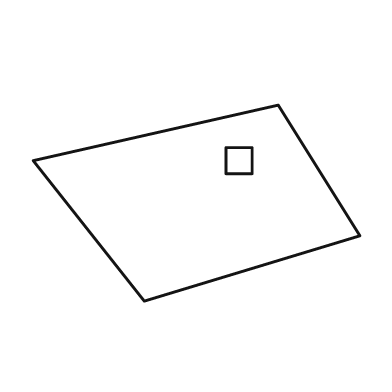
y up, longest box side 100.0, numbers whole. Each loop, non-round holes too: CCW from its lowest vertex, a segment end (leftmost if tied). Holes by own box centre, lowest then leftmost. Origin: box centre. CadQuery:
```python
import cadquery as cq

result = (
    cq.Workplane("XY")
    .moveTo(-16.0, -30.0)
    .lineTo(50.0, -10.0)
    .lineTo(25.0, 30.0)
    .lineTo(-50.0, 13.0)
    .close()
    .moveTo(9.0, 9.0)
    .lineTo(17.0, 9.0)
    .lineTo(17.0, 17.0)
    .lineTo(9.0, 17.0)
    .close()
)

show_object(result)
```